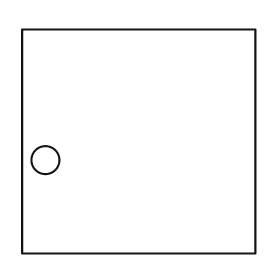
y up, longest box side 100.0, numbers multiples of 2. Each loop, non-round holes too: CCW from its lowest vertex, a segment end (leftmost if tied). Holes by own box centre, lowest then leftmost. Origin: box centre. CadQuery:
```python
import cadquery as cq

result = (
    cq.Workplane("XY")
    .moveTo(-50.0, -48.0)
    .lineTo(50.0, -48.0)
    .lineTo(50.0, 48.0)
    .lineTo(-50.0, 48.0)
    .close()
    .moveTo(-40.0, -8.0)
    .circle(6.0)
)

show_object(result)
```